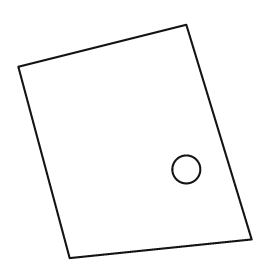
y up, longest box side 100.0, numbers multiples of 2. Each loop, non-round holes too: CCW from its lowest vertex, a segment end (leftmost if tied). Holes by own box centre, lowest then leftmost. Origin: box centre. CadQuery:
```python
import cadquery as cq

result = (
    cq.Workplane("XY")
    .moveTo(-28.0, -50.0)
    .lineTo(50.0, -42.0)
    .lineTo(22.0, 50.0)
    .lineTo(-50.0, 32.0)
    .close()
    .moveTo(22.0, -12.0)
    .circle(6.0)
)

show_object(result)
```